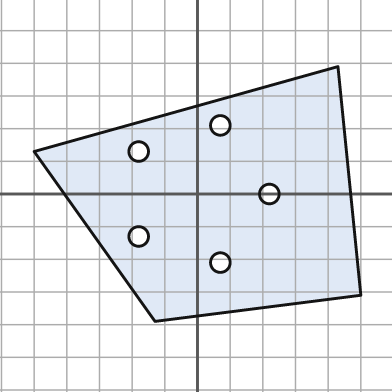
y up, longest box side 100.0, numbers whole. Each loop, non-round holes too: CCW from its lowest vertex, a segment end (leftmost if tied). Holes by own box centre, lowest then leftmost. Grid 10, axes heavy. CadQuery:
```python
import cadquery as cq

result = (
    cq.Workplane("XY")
    .moveTo(-13.0, -39.0)
    .lineTo(50.0, -31.0)
    .lineTo(43.0, 39.0)
    .lineTo(-50.0, 13.0)
    .close()
    .moveTo(7.0, -21.0)
    .circle(3.0)
    .moveTo(-18.0, -13.0)
    .circle(3.0)
    .moveTo(22.0, 0.0)
    .circle(3.0)
    .moveTo(-18.0, 13.0)
    .circle(3.0)
    .moveTo(7.0, 21.0)
    .circle(3.0)
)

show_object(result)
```